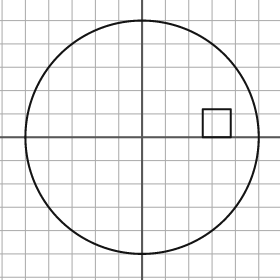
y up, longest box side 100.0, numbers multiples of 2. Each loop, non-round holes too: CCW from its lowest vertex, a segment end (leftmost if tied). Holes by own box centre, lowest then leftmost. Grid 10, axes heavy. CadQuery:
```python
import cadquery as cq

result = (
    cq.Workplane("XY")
    .moveTo(0.0, 0.0)
    .circle(50.0)
    .moveTo(26.0, 0.0)
    .lineTo(38.0, 0.0)
    .lineTo(38.0, 12.0)
    .lineTo(26.0, 12.0)
    .close()
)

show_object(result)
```